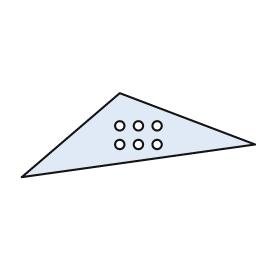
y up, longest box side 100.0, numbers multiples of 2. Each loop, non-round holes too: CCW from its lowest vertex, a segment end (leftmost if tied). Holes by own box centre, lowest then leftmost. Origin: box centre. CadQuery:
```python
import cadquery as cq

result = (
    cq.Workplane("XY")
    .moveTo(-50.0, -18.0)
    .lineTo(50.0, -4.0)
    .lineTo(-8.0, 18.0)
    .close()
    .moveTo(-8.0, -4.0)
    .circle(2.0)
    .moveTo(0.0, -4.0)
    .circle(2.0)
    .moveTo(8.0, -4.0)
    .circle(2.0)
    .moveTo(-8.0, 4.0)
    .circle(2.0)
    .moveTo(0.0, 4.0)
    .circle(2.0)
    .moveTo(8.0, 4.0)
    .circle(2.0)
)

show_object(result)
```